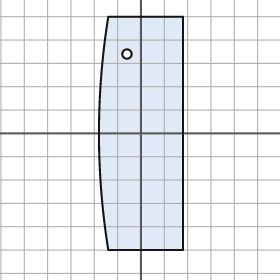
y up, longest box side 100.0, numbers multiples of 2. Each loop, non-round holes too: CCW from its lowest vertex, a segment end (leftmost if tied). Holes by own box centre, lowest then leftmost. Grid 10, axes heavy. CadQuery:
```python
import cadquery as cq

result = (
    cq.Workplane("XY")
    .moveTo(-14.0, -50.0)
    .lineTo(18.0, -50.0)
    .lineTo(18.0, 50.0)
    .lineTo(-14.0, 50.0)
    .threePointArc((-18.0, 0.0), (-14.0, -50.0))
    .close()
    .moveTo(-6.0, 34.0)
    .circle(2.0)
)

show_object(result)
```